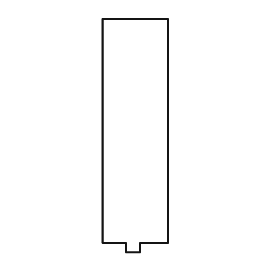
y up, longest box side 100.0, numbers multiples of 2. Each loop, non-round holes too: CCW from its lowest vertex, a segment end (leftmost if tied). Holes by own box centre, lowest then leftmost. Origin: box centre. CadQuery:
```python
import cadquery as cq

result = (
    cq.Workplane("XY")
    .moveTo(-4.0, -50.0)
    .lineTo(2.0, -50.0)
    .lineTo(2.0, -46.0)
    .lineTo(14.0, -46.0)
    .lineTo(14.0, 50.0)
    .lineTo(-14.0, 50.0)
    .lineTo(-14.0, -46.0)
    .lineTo(-4.0, -46.0)
    .close()
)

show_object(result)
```